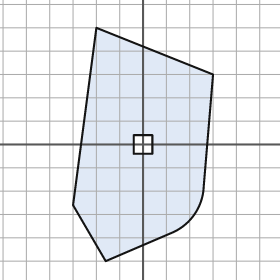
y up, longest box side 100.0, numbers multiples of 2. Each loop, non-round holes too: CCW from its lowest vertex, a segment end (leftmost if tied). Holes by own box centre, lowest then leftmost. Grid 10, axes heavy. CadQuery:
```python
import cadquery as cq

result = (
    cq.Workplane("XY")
    .moveTo(-16.0, -50.0)
    .lineTo(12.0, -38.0)
    .threePointArc((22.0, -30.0), (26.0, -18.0))
    .lineTo(30.0, 30.0)
    .lineTo(-20.0, 50.0)
    .lineTo(-30.0, -26.0)
    .close()
    .moveTo(-4.0, -4.0)
    .lineTo(4.0, -4.0)
    .lineTo(4.0, 4.0)
    .lineTo(-4.0, 4.0)
    .close()
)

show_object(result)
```